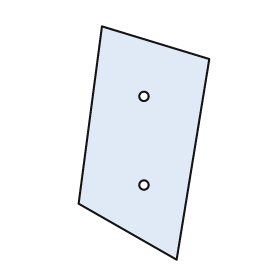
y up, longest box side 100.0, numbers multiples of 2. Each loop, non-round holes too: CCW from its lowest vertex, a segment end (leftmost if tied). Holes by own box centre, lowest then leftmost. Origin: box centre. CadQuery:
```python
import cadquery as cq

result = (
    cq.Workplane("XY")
    .moveTo(14.0, -50.0)
    .lineTo(28.0, 36.0)
    .lineTo(-18.0, 50.0)
    .lineTo(-28.0, -26.0)
    .close()
    .moveTo(0.0, -18.0)
    .circle(2.0)
    .moveTo(0.0, 20.0)
    .circle(2.0)
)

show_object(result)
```